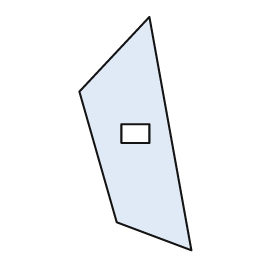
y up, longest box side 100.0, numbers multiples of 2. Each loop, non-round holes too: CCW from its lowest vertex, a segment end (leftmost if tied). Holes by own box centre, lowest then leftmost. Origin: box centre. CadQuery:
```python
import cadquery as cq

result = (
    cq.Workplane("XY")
    .moveTo(24.0, -50.0)
    .lineTo(6.0, 50.0)
    .lineTo(-24.0, 18.0)
    .lineTo(-8.0, -38.0)
    .close()
    .moveTo(-6.0, -4.0)
    .lineTo(6.0, -4.0)
    .lineTo(6.0, 4.0)
    .lineTo(-6.0, 4.0)
    .close()
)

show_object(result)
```